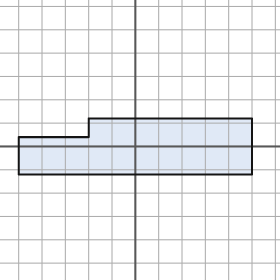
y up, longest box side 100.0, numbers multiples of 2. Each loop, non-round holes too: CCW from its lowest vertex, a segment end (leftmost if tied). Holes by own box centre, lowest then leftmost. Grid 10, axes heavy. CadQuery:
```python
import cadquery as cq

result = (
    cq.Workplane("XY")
    .moveTo(-50.0, -12.0)
    .lineTo(50.0, -12.0)
    .lineTo(50.0, 12.0)
    .lineTo(-20.0, 12.0)
    .lineTo(-20.0, 4.0)
    .lineTo(-50.0, 4.0)
    .close()
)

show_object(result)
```